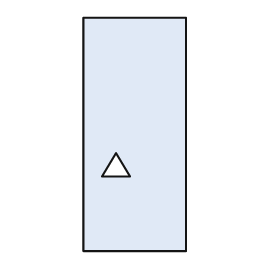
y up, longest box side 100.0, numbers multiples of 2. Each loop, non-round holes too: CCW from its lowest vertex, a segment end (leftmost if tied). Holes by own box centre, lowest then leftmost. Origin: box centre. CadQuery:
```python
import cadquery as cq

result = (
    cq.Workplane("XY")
    .moveTo(-22.0, -50.0)
    .lineTo(22.0, -50.0)
    .lineTo(22.0, 50.0)
    .lineTo(-22.0, 50.0)
    .close()
    .moveTo(-14.0, -18.0)
    .lineTo(-2.0, -18.0)
    .lineTo(-8.0, -8.0)
    .close()
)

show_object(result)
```